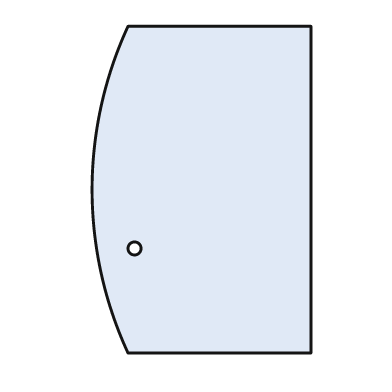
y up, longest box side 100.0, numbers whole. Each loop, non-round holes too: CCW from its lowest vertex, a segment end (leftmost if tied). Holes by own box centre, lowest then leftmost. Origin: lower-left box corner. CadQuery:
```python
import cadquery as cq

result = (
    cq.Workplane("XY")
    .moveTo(11.0, 0.0)
    .lineTo(67.0, 0.0)
    .lineTo(67.0, 100.0)
    .lineTo(11.0, 100.0)
    .threePointArc((0.0, 50.0), (11.0, 0.0))
    .close()
    .moveTo(13.0, 32.0)
    .circle(2.0)
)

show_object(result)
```